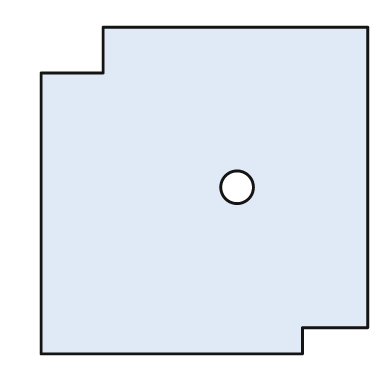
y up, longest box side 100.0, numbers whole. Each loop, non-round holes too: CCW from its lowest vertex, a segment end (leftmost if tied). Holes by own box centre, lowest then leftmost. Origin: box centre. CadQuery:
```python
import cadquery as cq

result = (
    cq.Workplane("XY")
    .moveTo(-50.0, -50.0)
    .lineTo(30.0, -50.0)
    .lineTo(30.0, -42.0)
    .lineTo(50.0, -42.0)
    .lineTo(50.0, 50.0)
    .lineTo(-31.0, 50.0)
    .lineTo(-31.0, 36.0)
    .lineTo(-50.0, 36.0)
    .close()
    .moveTo(10.0, 1.0)
    .circle(5.0)
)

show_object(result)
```